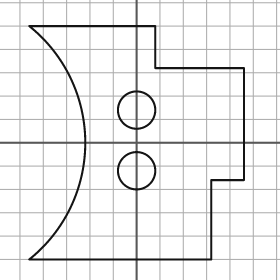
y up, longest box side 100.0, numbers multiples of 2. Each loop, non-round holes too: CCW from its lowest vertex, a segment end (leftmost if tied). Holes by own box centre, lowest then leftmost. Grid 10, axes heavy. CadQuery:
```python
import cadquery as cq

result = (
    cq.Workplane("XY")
    .moveTo(-46.0, -50.0)
    .lineTo(32.0, -50.0)
    .lineTo(32.0, -16.0)
    .lineTo(46.0, -16.0)
    .lineTo(46.0, 32.0)
    .lineTo(8.0, 32.0)
    .lineTo(8.0, 50.0)
    .lineTo(-46.0, 50.0)
    .threePointArc((-22.0, 0.0), (-46.0, -50.0))
    .close()
    .moveTo(0.0, -12.0)
    .circle(8.0)
    .moveTo(0.0, 14.0)
    .circle(8.0)
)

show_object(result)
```